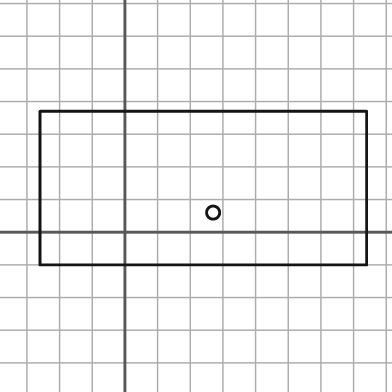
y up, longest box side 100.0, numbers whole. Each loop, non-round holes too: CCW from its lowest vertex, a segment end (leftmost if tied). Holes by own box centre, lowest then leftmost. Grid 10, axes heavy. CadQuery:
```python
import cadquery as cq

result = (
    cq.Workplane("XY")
    .moveTo(-26.0, -10.0)
    .lineTo(74.0, -10.0)
    .lineTo(74.0, 37.0)
    .lineTo(-26.0, 37.0)
    .close()
    .moveTo(27.0, 6.0)
    .circle(2.0)
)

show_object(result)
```